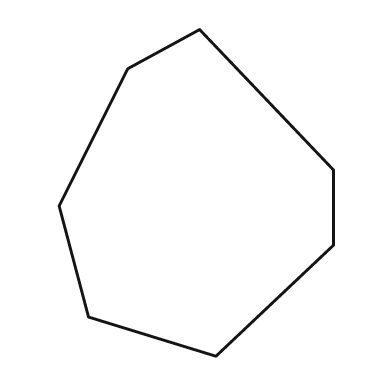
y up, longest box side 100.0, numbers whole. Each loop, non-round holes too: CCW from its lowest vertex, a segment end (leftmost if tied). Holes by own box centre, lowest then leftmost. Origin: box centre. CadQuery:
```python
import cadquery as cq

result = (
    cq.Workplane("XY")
    .moveTo(6.0, -50.0)
    .lineTo(42.0, -16.0)
    .lineTo(42.0, 7.0)
    .lineTo(1.0, 50.0)
    .lineTo(-21.0, 38.0)
    .lineTo(-42.0, -4.0)
    .lineTo(-33.0, -38.0)
    .close()
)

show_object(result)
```